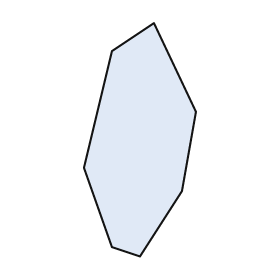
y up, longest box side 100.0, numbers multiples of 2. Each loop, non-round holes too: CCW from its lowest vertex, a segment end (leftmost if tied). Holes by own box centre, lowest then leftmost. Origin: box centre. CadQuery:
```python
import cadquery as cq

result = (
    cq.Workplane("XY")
    .moveTo(0.0, -50.0)
    .lineTo(18.0, -22.0)
    .lineTo(24.0, 12.0)
    .lineTo(6.0, 50.0)
    .lineTo(-12.0, 38.0)
    .lineTo(-24.0, -12.0)
    .lineTo(-12.0, -46.0)
    .close()
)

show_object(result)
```